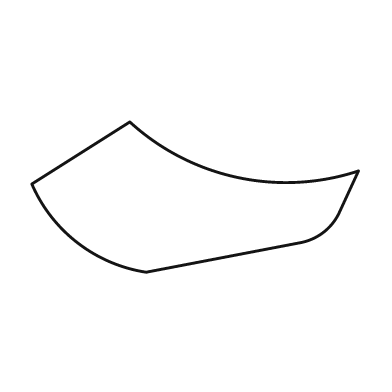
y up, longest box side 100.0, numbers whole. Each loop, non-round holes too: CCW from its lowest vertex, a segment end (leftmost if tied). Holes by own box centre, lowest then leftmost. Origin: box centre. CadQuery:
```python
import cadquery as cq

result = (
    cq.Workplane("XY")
    .moveTo(-15.0, -23.0)
    .lineTo(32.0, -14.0)
    .threePointArc((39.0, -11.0), (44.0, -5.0))
    .lineTo(50.0, 8.0)
    .threePointArc((13.0, 6.0), (-20.0, 23.0))
    .lineTo(-50.0, 4.0)
    .threePointArc((-36.0, -14.0), (-15.0, -23.0))
    .close()
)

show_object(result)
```